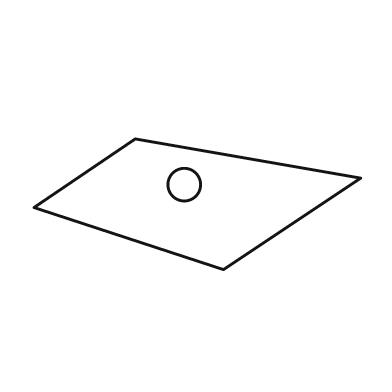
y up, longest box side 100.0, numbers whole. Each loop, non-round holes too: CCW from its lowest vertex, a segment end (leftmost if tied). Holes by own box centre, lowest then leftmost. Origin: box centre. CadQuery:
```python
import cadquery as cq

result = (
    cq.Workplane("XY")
    .moveTo(8.0, -20.0)
    .lineTo(50.0, 8.0)
    .lineTo(-19.0, 20.0)
    .lineTo(-50.0, -1.0)
    .close()
    .moveTo(-4.0, 6.0)
    .circle(5.0)
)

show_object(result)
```